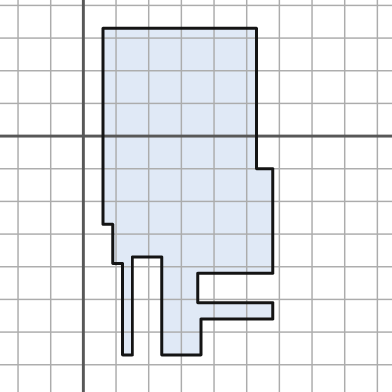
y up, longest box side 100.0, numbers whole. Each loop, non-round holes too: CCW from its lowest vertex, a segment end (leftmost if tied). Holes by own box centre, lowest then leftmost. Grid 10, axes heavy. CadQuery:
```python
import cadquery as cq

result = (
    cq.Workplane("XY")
    .moveTo(12.0, -67.0)
    .lineTo(15.0, -67.0)
    .lineTo(15.0, -37.0)
    .lineTo(24.0, -37.0)
    .lineTo(24.0, -67.0)
    .lineTo(36.0, -67.0)
    .lineTo(36.0, -56.0)
    .lineTo(58.0, -56.0)
    .lineTo(58.0, -51.0)
    .lineTo(35.0, -51.0)
    .lineTo(35.0, -42.0)
    .lineTo(58.0, -42.0)
    .lineTo(58.0, -10.0)
    .lineTo(53.0, -10.0)
    .lineTo(53.0, 33.0)
    .lineTo(6.0, 33.0)
    .lineTo(6.0, -27.0)
    .lineTo(9.0, -27.0)
    .lineTo(9.0, -39.0)
    .lineTo(12.0, -39.0)
    .close()
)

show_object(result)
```